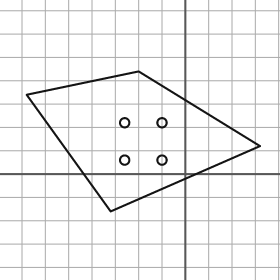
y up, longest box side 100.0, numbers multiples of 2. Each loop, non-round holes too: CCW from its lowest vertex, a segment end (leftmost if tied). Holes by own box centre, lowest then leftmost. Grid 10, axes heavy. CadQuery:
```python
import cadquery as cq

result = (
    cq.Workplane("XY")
    .moveTo(-32.0, -16.0)
    .lineTo(32.0, 12.0)
    .lineTo(-20.0, 44.0)
    .lineTo(-68.0, 34.0)
    .close()
    .moveTo(-26.0, 6.0)
    .circle(2.0)
    .moveTo(-10.0, 6.0)
    .circle(2.0)
    .moveTo(-26.0, 22.0)
    .circle(2.0)
    .moveTo(-10.0, 22.0)
    .circle(2.0)
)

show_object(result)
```